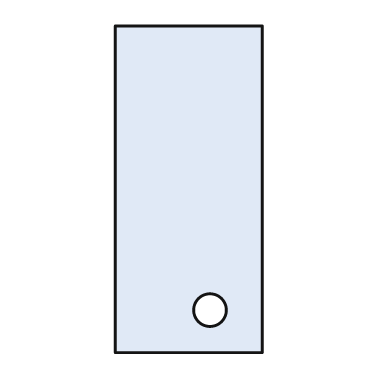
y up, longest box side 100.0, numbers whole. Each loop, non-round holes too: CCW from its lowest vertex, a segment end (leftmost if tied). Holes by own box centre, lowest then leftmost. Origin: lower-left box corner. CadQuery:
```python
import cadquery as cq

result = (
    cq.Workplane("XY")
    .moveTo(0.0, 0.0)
    .lineTo(45.0, 0.0)
    .lineTo(45.0, 100.0)
    .lineTo(0.0, 100.0)
    .close()
    .moveTo(29.0, 13.0)
    .circle(5.0)
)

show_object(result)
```